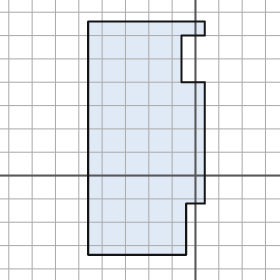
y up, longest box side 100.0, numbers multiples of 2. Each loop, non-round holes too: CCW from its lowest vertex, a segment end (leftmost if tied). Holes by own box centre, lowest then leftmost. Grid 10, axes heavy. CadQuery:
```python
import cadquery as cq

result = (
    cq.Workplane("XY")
    .moveTo(-46.0, -34.0)
    .lineTo(-4.0, -34.0)
    .lineTo(-4.0, -12.0)
    .lineTo(4.0, -12.0)
    .lineTo(4.0, 40.0)
    .lineTo(-6.0, 40.0)
    .lineTo(-6.0, 60.0)
    .lineTo(4.0, 60.0)
    .lineTo(4.0, 66.0)
    .lineTo(-46.0, 66.0)
    .close()
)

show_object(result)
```